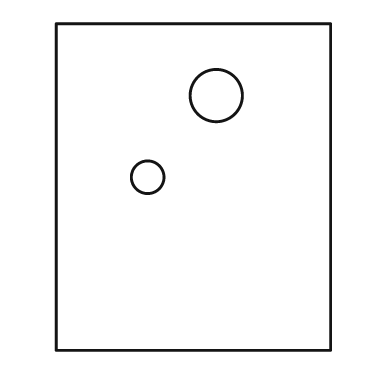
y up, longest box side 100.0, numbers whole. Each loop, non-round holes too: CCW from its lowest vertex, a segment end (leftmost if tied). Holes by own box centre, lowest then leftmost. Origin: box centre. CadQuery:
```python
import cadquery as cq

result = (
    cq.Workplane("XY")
    .moveTo(-42.0, -50.0)
    .lineTo(42.0, -50.0)
    .lineTo(42.0, 50.0)
    .lineTo(-42.0, 50.0)
    .close()
    .moveTo(-14.0, 3.0)
    .circle(5.0)
    .moveTo(7.0, 28.0)
    .circle(8.0)
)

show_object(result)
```